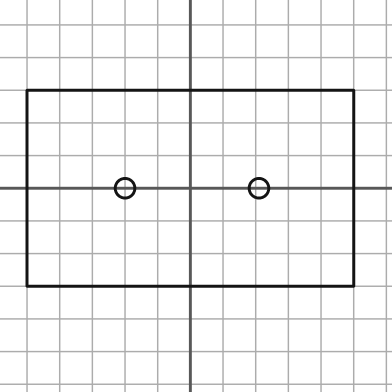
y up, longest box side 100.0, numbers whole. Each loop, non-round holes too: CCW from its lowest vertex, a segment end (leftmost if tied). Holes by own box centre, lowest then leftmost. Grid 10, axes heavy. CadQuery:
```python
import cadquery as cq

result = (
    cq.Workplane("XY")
    .moveTo(-50.0, -30.0)
    .lineTo(50.0, -30.0)
    .lineTo(50.0, 30.0)
    .lineTo(-50.0, 30.0)
    .close()
    .moveTo(-20.0, 0.0)
    .circle(3.0)
    .moveTo(21.0, 0.0)
    .circle(3.0)
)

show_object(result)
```